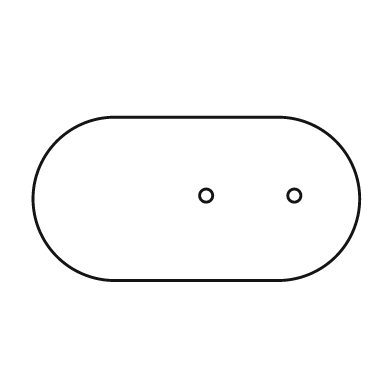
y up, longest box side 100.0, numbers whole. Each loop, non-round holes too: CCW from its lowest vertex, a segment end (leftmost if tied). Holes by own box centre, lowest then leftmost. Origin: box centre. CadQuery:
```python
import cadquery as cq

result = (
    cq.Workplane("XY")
    .moveTo(-25.0, -25.0)
    .lineTo(25.0, -25.0)
    .threePointArc((50.0, 0.0), (25.0, 25.0))
    .lineTo(-25.0, 25.0)
    .threePointArc((-50.0, 0.0), (-25.0, -25.0))
    .close()
    .moveTo(3.0, 1.0)
    .circle(2.0)
    .moveTo(30.0, 1.0)
    .circle(2.0)
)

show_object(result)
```